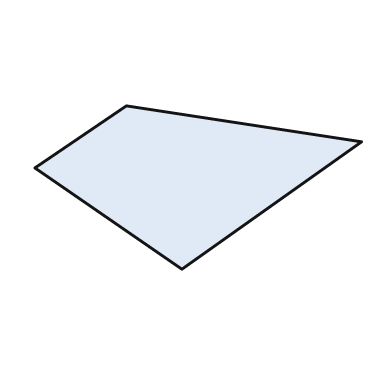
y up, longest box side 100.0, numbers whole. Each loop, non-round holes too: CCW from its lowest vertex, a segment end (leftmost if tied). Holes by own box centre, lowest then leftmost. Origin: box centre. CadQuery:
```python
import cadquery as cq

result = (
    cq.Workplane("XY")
    .moveTo(-5.0, -25.0)
    .lineTo(50.0, 14.0)
    .lineTo(-22.0, 25.0)
    .lineTo(-50.0, 6.0)
    .close()
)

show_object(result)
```